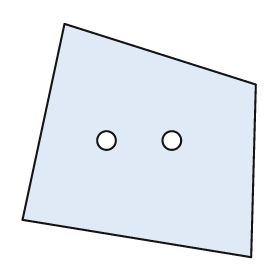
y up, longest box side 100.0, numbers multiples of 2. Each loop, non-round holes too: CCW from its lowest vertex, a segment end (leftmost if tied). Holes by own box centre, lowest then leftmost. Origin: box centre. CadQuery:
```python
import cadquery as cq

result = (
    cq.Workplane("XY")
    .moveTo(48.0, -50.0)
    .lineTo(50.0, 24.0)
    .lineTo(-32.0, 50.0)
    .lineTo(-50.0, -34.0)
    .close()
    .moveTo(-14.0, 0.0)
    .circle(4.0)
    .moveTo(14.0, 0.0)
    .circle(4.0)
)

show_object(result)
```